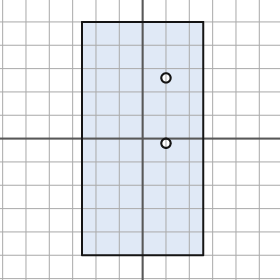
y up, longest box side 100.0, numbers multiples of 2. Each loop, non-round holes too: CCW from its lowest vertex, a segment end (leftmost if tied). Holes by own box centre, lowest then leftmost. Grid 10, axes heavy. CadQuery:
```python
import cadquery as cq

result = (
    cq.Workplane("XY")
    .moveTo(-26.0, -50.0)
    .lineTo(26.0, -50.0)
    .lineTo(26.0, 50.0)
    .lineTo(-26.0, 50.0)
    .close()
    .moveTo(10.0, -2.0)
    .circle(2.0)
    .moveTo(10.0, 26.0)
    .circle(2.0)
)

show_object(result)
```